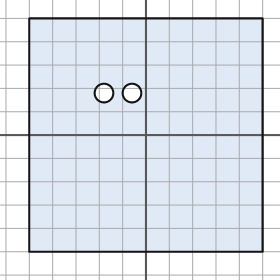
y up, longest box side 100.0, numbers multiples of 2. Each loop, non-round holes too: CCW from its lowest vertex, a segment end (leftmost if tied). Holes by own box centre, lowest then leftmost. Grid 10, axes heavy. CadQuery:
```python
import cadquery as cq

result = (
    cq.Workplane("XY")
    .moveTo(-50.0, -50.0)
    .lineTo(50.0, -50.0)
    .lineTo(50.0, 50.0)
    .lineTo(-50.0, 50.0)
    .close()
    .moveTo(-18.0, 18.0)
    .circle(4.0)
    .moveTo(-6.0, 18.0)
    .circle(4.0)
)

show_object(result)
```